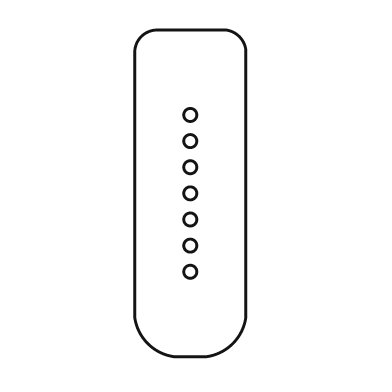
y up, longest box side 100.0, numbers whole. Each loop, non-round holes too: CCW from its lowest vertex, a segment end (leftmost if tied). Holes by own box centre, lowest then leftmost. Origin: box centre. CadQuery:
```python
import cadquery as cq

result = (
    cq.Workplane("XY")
    .moveTo(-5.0, -50.0)
    .lineTo(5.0, -50.0)
    .threePointArc((13.0, -46.0), (17.0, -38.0))
    .lineTo(17.0, 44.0)
    .threePointArc((15.0, 48.0), (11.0, 50.0))
    .lineTo(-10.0, 50.0)
    .threePointArc((-15.0, 48.0), (-17.0, 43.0))
    .lineTo(-17.0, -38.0)
    .threePointArc((-13.0, -46.0), (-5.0, -50.0))
    .close()
    .moveTo(0.0, -24.0)
    .circle(2.0)
    .moveTo(0.0, -16.0)
    .circle(2.0)
    .moveTo(0.0, -8.0)
    .circle(2.0)
    .moveTo(0.0, 0.0)
    .circle(2.0)
    .moveTo(0.0, 8.0)
    .circle(2.0)
    .moveTo(0.0, 16.0)
    .circle(2.0)
    .moveTo(0.0, 24.0)
    .circle(2.0)
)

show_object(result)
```